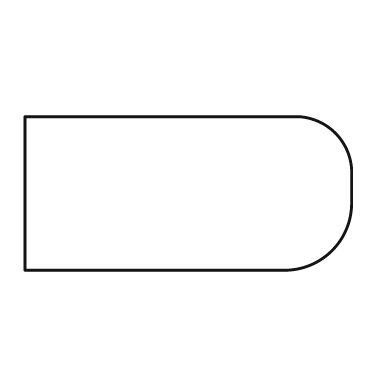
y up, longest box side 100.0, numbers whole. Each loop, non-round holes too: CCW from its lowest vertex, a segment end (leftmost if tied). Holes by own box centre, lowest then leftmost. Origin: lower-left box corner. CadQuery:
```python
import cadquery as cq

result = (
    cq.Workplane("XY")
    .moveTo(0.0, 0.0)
    .lineTo(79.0, 0.0)
    .threePointArc((94.0, 6.0), (100.0, 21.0))
    .lineTo(100.0, 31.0)
    .threePointArc((95.0, 42.0), (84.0, 47.0))
    .lineTo(0.0, 47.0)
    .close()
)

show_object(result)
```